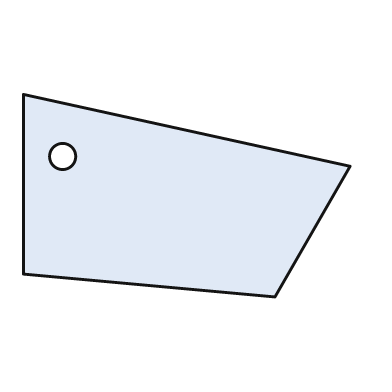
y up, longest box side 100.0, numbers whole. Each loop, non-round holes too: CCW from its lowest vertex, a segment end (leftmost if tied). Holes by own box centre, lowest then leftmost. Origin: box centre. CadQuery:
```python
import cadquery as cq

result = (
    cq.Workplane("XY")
    .moveTo(27.0, -31.0)
    .lineTo(50.0, 9.0)
    .lineTo(-50.0, 31.0)
    .lineTo(-50.0, -24.0)
    .close()
    .moveTo(-38.0, 12.0)
    .circle(4.0)
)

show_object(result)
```